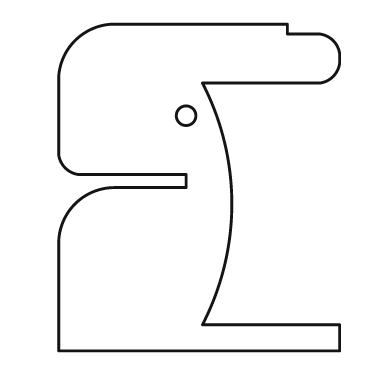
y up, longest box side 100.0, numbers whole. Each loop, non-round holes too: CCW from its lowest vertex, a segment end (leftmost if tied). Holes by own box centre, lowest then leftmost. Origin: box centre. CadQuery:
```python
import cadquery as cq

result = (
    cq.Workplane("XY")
    .moveTo(-43.0, -50.0)
    .lineTo(43.0, -50.0)
    .lineTo(43.0, -42.0)
    .lineTo(1.0, -42.0)
    .threePointArc((10.0, -5.0), (1.0, 32.0))
    .lineTo(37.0, 32.0)
    .threePointArc((41.0, 34.0), (43.0, 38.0))
    .lineTo(43.0, 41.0)
    .threePointArc((41.0, 45.0), (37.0, 47.0))
    .lineTo(27.0, 47.0)
    .lineTo(27.0, 50.0)
    .lineTo(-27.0, 50.0)
    .threePointArc((-38.0, 45.0), (-43.0, 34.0))
    .lineTo(-43.0, 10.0)
    .threePointArc((-41.0, 6.0), (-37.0, 4.0))
    .lineTo(-4.0, 4.0)
    .lineTo(-4.0, 0.0)
    .lineTo(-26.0, 0.0)
    .threePointArc((-38.0, -5.0), (-43.0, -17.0))
    .close()
    .moveTo(-4.0, 22.0)
    .circle(3.0)
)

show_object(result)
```